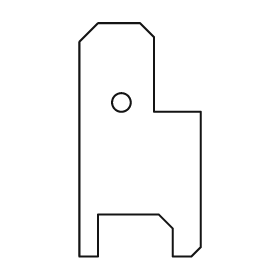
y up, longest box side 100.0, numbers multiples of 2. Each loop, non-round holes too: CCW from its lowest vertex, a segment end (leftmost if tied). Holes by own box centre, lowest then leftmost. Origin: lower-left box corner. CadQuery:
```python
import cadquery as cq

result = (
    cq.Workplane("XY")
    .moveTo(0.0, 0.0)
    .lineTo(8.0, 0.0)
    .lineTo(8.0, 18.0)
    .lineTo(34.0, 18.0)
    .lineTo(40.0, 12.0)
    .lineTo(40.0, 0.0)
    .lineTo(48.0, 0.0)
    .lineTo(52.0, 4.0)
    .lineTo(52.0, 62.0)
    .lineTo(32.0, 62.0)
    .lineTo(32.0, 94.0)
    .lineTo(26.0, 100.0)
    .lineTo(8.0, 100.0)
    .lineTo(0.0, 92.0)
    .close()
    .moveTo(18.0, 66.0)
    .circle(4.0)
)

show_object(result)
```